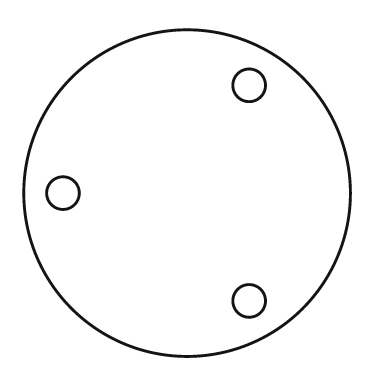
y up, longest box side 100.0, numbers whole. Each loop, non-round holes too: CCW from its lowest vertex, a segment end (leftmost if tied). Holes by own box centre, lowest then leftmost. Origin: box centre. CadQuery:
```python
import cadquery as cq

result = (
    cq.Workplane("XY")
    .moveTo(0.0, 0.0)
    .circle(50.0)
    .moveTo(19.0, -33.0)
    .circle(5.0)
    .moveTo(-38.0, 0.0)
    .circle(5.0)
    .moveTo(19.0, 33.0)
    .circle(5.0)
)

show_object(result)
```